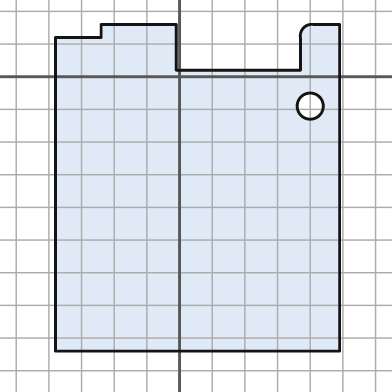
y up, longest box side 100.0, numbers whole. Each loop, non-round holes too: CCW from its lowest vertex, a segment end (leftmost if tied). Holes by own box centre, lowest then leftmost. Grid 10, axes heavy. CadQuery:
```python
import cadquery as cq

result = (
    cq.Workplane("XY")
    .moveTo(-38.0, -84.0)
    .lineTo(49.0, -84.0)
    .lineTo(49.0, 16.0)
    .lineTo(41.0, 16.0)
    .threePointArc((38.0, 15.0), (37.0, 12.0))
    .lineTo(37.0, 2.0)
    .lineTo(-1.0, 2.0)
    .lineTo(-1.0, 16.0)
    .lineTo(-24.0, 16.0)
    .lineTo(-24.0, 12.0)
    .lineTo(-38.0, 12.0)
    .close()
    .moveTo(40.0, -9.0)
    .circle(4.0)
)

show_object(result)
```